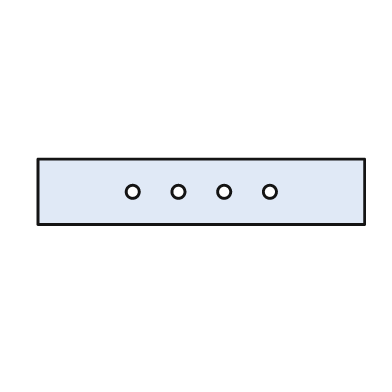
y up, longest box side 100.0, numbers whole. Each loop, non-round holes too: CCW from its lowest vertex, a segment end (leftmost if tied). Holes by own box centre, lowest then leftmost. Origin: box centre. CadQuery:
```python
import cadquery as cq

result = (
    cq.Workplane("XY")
    .moveTo(-50.0, -10.0)
    .lineTo(50.0, -10.0)
    .lineTo(50.0, 10.0)
    .lineTo(-50.0, 10.0)
    .close()
    .moveTo(-21.0, 0.0)
    .circle(2.0)
    .moveTo(-7.0, 0.0)
    .circle(2.0)
    .moveTo(7.0, 0.0)
    .circle(2.0)
    .moveTo(21.0, 0.0)
    .circle(2.0)
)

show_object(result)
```